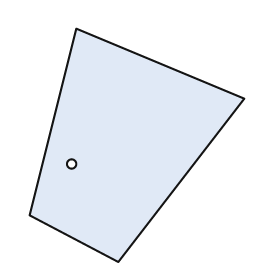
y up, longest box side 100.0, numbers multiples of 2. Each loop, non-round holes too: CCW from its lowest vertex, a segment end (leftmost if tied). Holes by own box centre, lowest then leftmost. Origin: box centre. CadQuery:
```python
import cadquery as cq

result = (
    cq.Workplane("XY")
    .moveTo(-8.0, -50.0)
    .lineTo(46.0, 20.0)
    .lineTo(-26.0, 50.0)
    .lineTo(-46.0, -30.0)
    .close()
    .moveTo(-28.0, -8.0)
    .circle(2.0)
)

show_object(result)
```